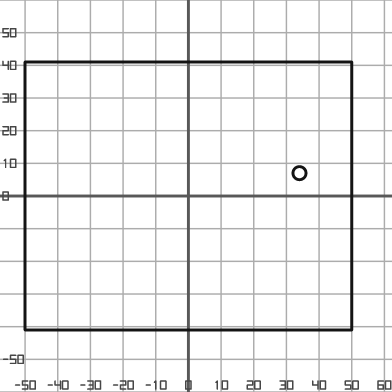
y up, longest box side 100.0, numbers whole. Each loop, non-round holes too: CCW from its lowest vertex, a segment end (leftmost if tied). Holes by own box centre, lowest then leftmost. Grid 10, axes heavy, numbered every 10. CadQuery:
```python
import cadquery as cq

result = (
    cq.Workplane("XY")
    .moveTo(-50.0, -41.0)
    .lineTo(50.0, -41.0)
    .lineTo(50.0, 41.0)
    .lineTo(-50.0, 41.0)
    .close()
    .moveTo(34.0, 7.0)
    .circle(2.0)
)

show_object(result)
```